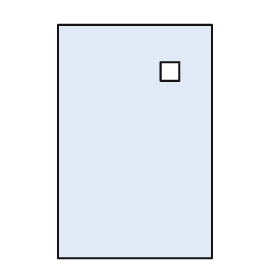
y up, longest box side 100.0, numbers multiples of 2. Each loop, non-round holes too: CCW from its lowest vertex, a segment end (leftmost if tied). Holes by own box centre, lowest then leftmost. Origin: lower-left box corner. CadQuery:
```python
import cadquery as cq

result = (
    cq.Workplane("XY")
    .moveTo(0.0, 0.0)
    .lineTo(66.0, 0.0)
    .lineTo(66.0, 100.0)
    .lineTo(0.0, 100.0)
    .close()
    .moveTo(44.0, 76.0)
    .lineTo(52.0, 76.0)
    .lineTo(52.0, 84.0)
    .lineTo(44.0, 84.0)
    .close()
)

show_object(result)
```